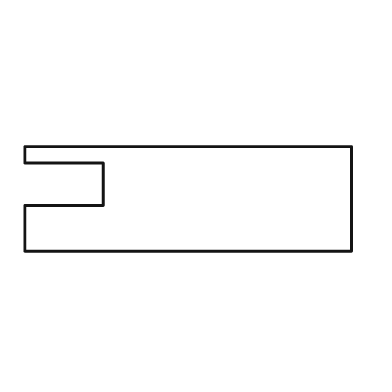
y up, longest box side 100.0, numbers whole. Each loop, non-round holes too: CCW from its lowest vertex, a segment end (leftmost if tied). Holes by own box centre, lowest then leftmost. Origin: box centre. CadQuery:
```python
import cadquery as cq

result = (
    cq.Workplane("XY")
    .moveTo(-50.0, -16.0)
    .lineTo(50.0, -16.0)
    .lineTo(50.0, 16.0)
    .lineTo(-50.0, 16.0)
    .lineTo(-50.0, 11.0)
    .lineTo(-26.0, 11.0)
    .lineTo(-26.0, -2.0)
    .lineTo(-50.0, -2.0)
    .close()
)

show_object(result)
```